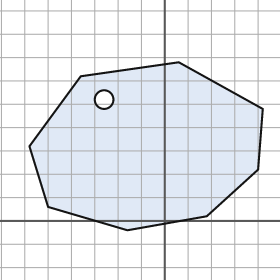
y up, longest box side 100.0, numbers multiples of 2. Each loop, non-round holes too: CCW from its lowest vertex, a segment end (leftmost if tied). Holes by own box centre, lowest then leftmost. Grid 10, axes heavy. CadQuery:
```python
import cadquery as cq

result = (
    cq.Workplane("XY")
    .moveTo(-16.0, -4.0)
    .lineTo(18.0, 2.0)
    .lineTo(40.0, 22.0)
    .lineTo(42.0, 48.0)
    .lineTo(6.0, 68.0)
    .lineTo(-36.0, 62.0)
    .lineTo(-58.0, 32.0)
    .lineTo(-50.0, 6.0)
    .close()
    .moveTo(-26.0, 52.0)
    .circle(4.0)
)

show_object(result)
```